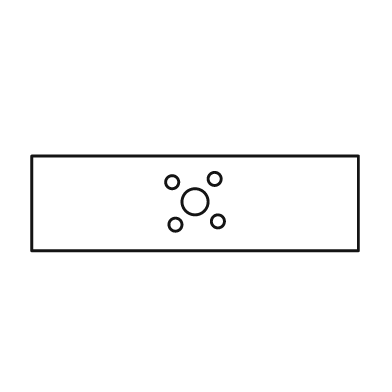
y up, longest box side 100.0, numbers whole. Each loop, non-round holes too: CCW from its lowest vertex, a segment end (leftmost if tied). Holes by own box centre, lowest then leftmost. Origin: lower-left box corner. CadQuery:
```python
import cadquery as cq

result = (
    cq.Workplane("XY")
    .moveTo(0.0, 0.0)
    .lineTo(100.0, 0.0)
    .lineTo(100.0, 29.0)
    .lineTo(0.0, 29.0)
    .close()
    .moveTo(44.0, 8.0)
    .circle(2.0)
    .moveTo(57.0, 9.0)
    .circle(2.0)
    .moveTo(50.0, 15.0)
    .circle(4.0)
    .moveTo(43.0, 21.0)
    .circle(2.0)
    .moveTo(56.0, 22.0)
    .circle(2.0)
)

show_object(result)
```